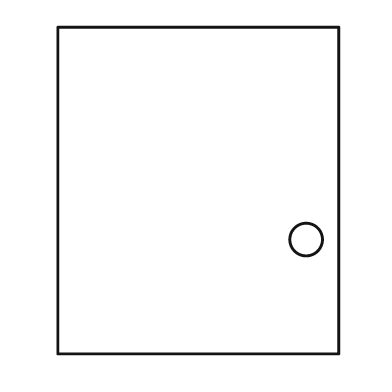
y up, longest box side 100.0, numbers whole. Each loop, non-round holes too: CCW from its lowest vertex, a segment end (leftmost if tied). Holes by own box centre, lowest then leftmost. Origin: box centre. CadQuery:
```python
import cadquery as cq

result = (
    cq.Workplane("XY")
    .moveTo(-43.0, -50.0)
    .lineTo(43.0, -50.0)
    .lineTo(43.0, 50.0)
    .lineTo(-43.0, 50.0)
    .close()
    .moveTo(33.0, -15.0)
    .circle(5.0)
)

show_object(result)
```